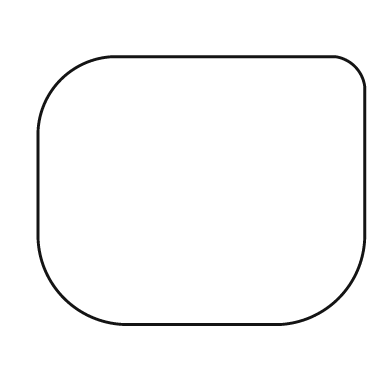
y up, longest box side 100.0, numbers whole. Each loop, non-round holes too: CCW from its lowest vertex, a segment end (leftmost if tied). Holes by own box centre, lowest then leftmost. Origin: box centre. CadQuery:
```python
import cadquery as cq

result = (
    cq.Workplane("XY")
    .moveTo(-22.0, -41.0)
    .lineTo(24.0, -41.0)
    .threePointArc((42.0, -33.0), (50.0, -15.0))
    .lineTo(50.0, 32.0)
    .threePointArc((47.0, 38.0), (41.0, 41.0))
    .lineTo(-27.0, 41.0)
    .threePointArc((-43.0, 34.0), (-50.0, 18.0))
    .lineTo(-50.0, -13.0)
    .threePointArc((-42.0, -33.0), (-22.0, -41.0))
    .close()
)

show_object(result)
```